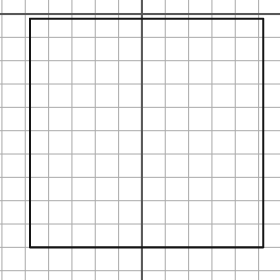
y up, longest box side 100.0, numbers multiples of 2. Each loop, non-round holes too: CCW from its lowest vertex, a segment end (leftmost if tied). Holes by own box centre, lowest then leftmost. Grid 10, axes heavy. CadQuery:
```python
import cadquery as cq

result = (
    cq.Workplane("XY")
    .moveTo(-48.0, -100.0)
    .lineTo(52.0, -100.0)
    .lineTo(52.0, -2.0)
    .lineTo(-48.0, -2.0)
    .close()
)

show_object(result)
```